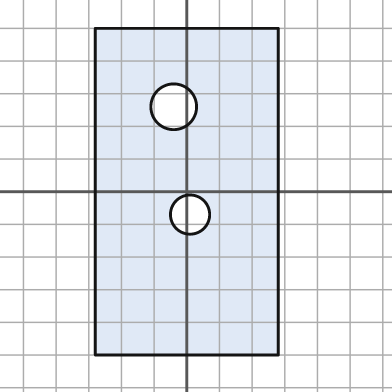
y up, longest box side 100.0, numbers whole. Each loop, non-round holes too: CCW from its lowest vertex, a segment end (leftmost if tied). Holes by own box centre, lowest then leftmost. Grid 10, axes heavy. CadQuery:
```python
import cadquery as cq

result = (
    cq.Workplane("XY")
    .moveTo(-28.0, -50.0)
    .lineTo(28.0, -50.0)
    .lineTo(28.0, 50.0)
    .lineTo(-28.0, 50.0)
    .close()
    .moveTo(1.0, -7.0)
    .circle(6.0)
    .moveTo(-4.0, 26.0)
    .circle(7.0)
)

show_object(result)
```